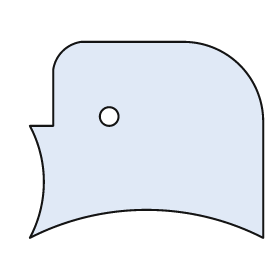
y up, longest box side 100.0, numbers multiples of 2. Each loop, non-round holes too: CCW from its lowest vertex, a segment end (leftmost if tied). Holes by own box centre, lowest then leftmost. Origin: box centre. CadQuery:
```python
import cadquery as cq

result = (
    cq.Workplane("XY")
    .moveTo(-50.0, -42.0)
    .threePointArc((0.0, -30.0), (50.0, -42.0))
    .lineTo(50.0, 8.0)
    .threePointArc((40.0, 32.0), (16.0, 42.0))
    .lineTo(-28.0, 42.0)
    .threePointArc((-36.0, 38.0), (-40.0, 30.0))
    .lineTo(-40.0, 6.0)
    .lineTo(-50.0, 6.0)
    .threePointArc((-44.0, -18.0), (-50.0, -42.0))
    .close()
    .moveTo(-16.0, 10.0)
    .circle(4.0)
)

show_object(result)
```